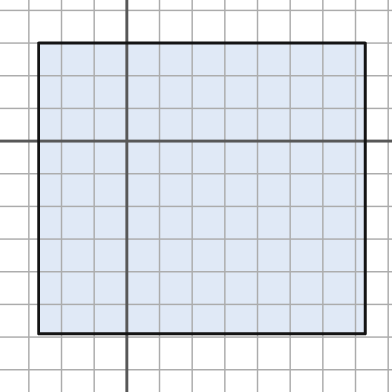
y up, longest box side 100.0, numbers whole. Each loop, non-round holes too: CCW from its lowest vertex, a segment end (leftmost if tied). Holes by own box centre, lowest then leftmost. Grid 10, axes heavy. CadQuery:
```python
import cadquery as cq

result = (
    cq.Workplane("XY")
    .moveTo(-27.0, -59.0)
    .lineTo(73.0, -59.0)
    .lineTo(73.0, 30.0)
    .lineTo(-27.0, 30.0)
    .close()
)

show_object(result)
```